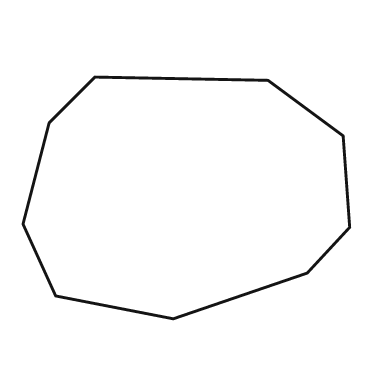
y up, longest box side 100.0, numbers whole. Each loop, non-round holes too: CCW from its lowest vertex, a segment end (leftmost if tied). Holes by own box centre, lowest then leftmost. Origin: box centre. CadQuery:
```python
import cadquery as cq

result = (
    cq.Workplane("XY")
    .moveTo(-4.0, -37.0)
    .lineTo(37.0, -23.0)
    .lineTo(50.0, -9.0)
    .lineTo(48.0, 19.0)
    .lineTo(25.0, 36.0)
    .lineTo(-28.0, 37.0)
    .lineTo(-42.0, 23.0)
    .lineTo(-50.0, -8.0)
    .lineTo(-40.0, -30.0)
    .close()
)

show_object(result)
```